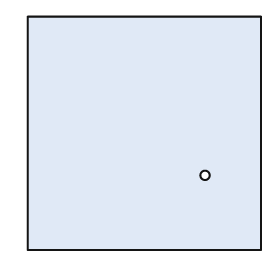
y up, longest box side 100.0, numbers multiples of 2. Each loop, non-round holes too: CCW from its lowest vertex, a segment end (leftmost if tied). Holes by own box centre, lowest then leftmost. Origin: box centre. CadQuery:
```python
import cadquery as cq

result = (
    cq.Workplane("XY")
    .moveTo(-50.0, -50.0)
    .lineTo(50.0, -50.0)
    .lineTo(50.0, 50.0)
    .lineTo(-50.0, 50.0)
    .close()
    .moveTo(26.0, -18.0)
    .circle(2.0)
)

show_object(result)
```